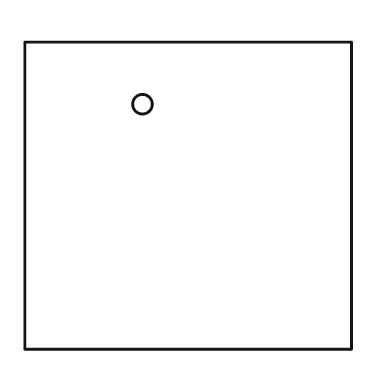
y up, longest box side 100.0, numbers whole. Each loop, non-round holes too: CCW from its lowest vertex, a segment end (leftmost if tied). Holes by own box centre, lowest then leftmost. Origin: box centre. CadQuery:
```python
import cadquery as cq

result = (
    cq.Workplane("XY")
    .moveTo(-50.0, -47.0)
    .lineTo(50.0, -47.0)
    .lineTo(50.0, 47.0)
    .lineTo(-50.0, 47.0)
    .close()
    .moveTo(-14.0, 28.0)
    .circle(3.0)
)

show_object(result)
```